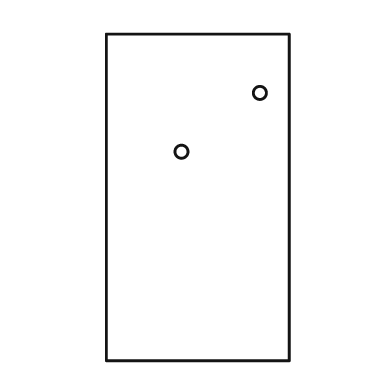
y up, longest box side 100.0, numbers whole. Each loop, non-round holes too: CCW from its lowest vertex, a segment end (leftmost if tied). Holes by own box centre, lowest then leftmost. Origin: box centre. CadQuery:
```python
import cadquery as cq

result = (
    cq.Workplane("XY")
    .moveTo(-28.0, -50.0)
    .lineTo(28.0, -50.0)
    .lineTo(28.0, 50.0)
    .lineTo(-28.0, 50.0)
    .close()
    .moveTo(-5.0, 14.0)
    .circle(2.0)
    .moveTo(19.0, 32.0)
    .circle(2.0)
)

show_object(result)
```